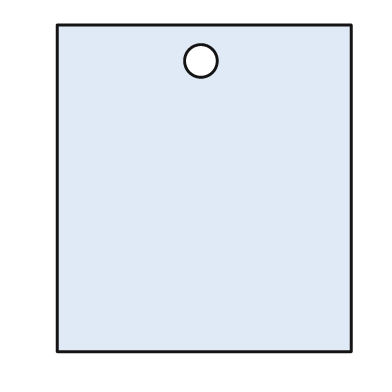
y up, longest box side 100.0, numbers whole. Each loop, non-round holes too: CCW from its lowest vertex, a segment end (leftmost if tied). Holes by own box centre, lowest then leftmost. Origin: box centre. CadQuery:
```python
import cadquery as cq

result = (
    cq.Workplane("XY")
    .moveTo(-45.0, -50.0)
    .lineTo(45.0, -50.0)
    .lineTo(45.0, 50.0)
    .lineTo(-45.0, 50.0)
    .close()
    .moveTo(-1.0, 39.0)
    .circle(5.0)
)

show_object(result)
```